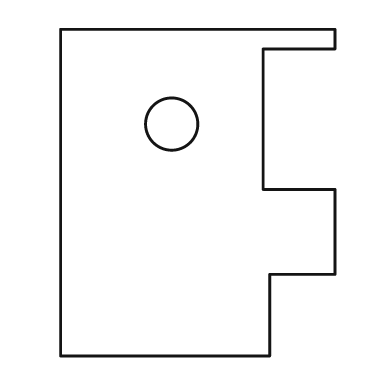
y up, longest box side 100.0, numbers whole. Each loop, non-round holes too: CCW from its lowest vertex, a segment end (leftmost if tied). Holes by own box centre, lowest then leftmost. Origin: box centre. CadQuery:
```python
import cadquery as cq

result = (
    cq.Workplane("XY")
    .moveTo(-42.0, -50.0)
    .lineTo(22.0, -50.0)
    .lineTo(22.0, -25.0)
    .lineTo(42.0, -25.0)
    .lineTo(42.0, 1.0)
    .lineTo(20.0, 1.0)
    .lineTo(20.0, 44.0)
    .lineTo(42.0, 44.0)
    .lineTo(42.0, 50.0)
    .lineTo(-42.0, 50.0)
    .close()
    .moveTo(-8.0, 21.0)
    .circle(8.0)
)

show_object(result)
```